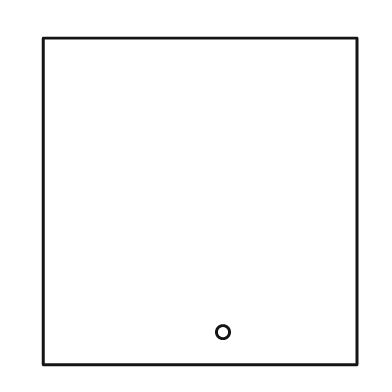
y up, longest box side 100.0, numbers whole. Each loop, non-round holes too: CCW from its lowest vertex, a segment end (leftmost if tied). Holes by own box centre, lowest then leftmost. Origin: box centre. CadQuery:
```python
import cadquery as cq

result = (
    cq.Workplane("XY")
    .moveTo(-48.0, -50.0)
    .lineTo(48.0, -50.0)
    .lineTo(48.0, 50.0)
    .lineTo(-48.0, 50.0)
    .close()
    .moveTo(7.0, -40.0)
    .circle(2.0)
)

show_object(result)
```